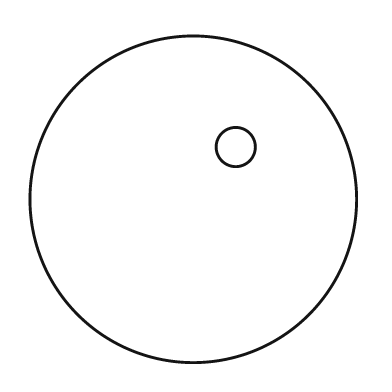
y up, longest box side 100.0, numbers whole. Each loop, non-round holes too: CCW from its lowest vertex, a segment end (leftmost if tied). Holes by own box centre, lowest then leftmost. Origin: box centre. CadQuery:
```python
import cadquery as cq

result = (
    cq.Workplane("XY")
    .moveTo(0.0, 0.0)
    .circle(50.0)
    .moveTo(13.0, 16.0)
    .circle(6.0)
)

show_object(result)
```